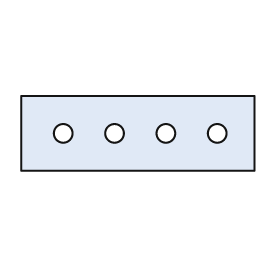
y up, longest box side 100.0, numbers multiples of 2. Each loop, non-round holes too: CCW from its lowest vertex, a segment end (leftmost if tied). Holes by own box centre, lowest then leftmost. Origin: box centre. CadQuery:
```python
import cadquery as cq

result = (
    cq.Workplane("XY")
    .moveTo(-50.0, -16.0)
    .lineTo(50.0, -16.0)
    .lineTo(50.0, 16.0)
    .lineTo(-50.0, 16.0)
    .close()
    .moveTo(-32.0, 0.0)
    .circle(4.0)
    .moveTo(-10.0, 0.0)
    .circle(4.0)
    .moveTo(12.0, 0.0)
    .circle(4.0)
    .moveTo(34.0, 0.0)
    .circle(4.0)
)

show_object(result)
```